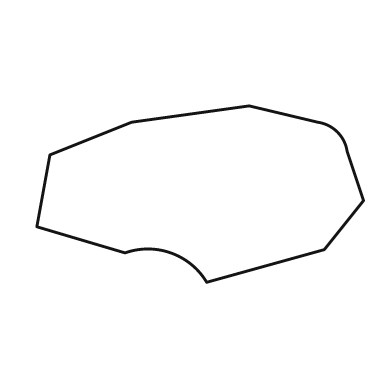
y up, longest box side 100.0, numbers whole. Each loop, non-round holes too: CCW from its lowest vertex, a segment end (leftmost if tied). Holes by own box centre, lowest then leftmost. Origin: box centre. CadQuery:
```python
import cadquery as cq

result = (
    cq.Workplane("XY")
    .moveTo(2.0, -27.0)
    .lineTo(38.0, -17.0)
    .lineTo(50.0, -2.0)
    .lineTo(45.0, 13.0)
    .threePointArc((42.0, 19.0), (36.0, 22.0))
    .lineTo(15.0, 27.0)
    .lineTo(-21.0, 22.0)
    .lineTo(-46.0, 12.0)
    .lineTo(-50.0, -10.0)
    .lineTo(-23.0, -18.0)
    .threePointArc((-9.0, -18.0), (2.0, -27.0))
    .close()
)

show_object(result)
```